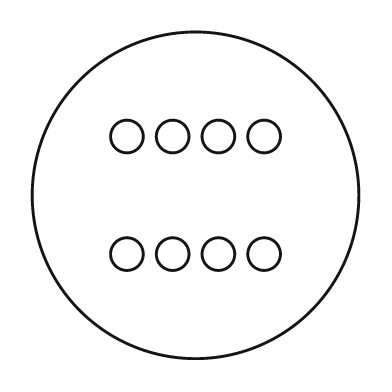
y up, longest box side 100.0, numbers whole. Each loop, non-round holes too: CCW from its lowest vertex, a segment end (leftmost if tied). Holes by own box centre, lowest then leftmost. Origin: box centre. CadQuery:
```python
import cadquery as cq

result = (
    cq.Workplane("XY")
    .moveTo(0.0, 0.0)
    .circle(50.0)
    .moveTo(-21.0, -18.0)
    .circle(5.0)
    .moveTo(-7.0, -18.0)
    .circle(5.0)
    .moveTo(7.0, -18.0)
    .circle(5.0)
    .moveTo(21.0, -18.0)
    .circle(5.0)
    .moveTo(-21.0, 18.0)
    .circle(5.0)
    .moveTo(-7.0, 18.0)
    .circle(5.0)
    .moveTo(7.0, 18.0)
    .circle(5.0)
    .moveTo(21.0, 18.0)
    .circle(5.0)
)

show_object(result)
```